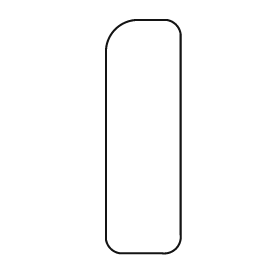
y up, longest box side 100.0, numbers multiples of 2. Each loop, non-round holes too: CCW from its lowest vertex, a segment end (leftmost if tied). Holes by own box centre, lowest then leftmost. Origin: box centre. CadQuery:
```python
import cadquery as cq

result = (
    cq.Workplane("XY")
    .moveTo(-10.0, -50.0)
    .lineTo(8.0, -50.0)
    .threePointArc((14.0, -48.0), (16.0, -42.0))
    .lineTo(16.0, 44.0)
    .threePointArc((14.0, 48.0), (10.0, 50.0))
    .lineTo(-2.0, 50.0)
    .threePointArc((-12.0, 46.0), (-16.0, 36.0))
    .lineTo(-16.0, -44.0)
    .threePointArc((-14.0, -48.0), (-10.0, -50.0))
    .close()
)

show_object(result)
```